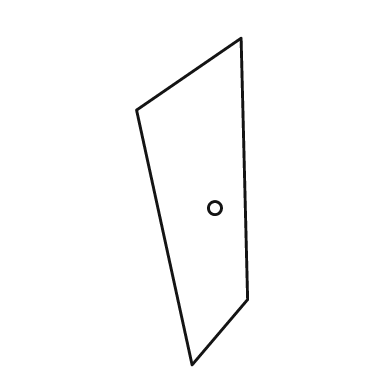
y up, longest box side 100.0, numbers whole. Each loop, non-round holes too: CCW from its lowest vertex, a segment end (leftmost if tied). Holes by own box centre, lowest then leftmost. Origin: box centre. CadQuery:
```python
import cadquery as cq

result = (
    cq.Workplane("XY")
    .moveTo(0.0, -50.0)
    .lineTo(17.0, -30.0)
    .lineTo(15.0, 50.0)
    .lineTo(-17.0, 28.0)
    .close()
    .moveTo(7.0, -2.0)
    .circle(2.0)
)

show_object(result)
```